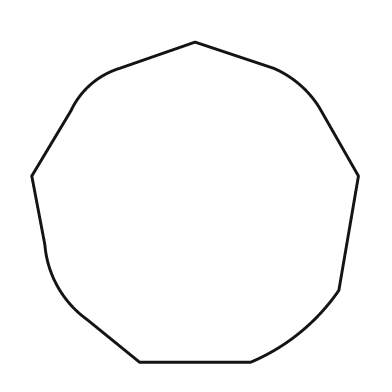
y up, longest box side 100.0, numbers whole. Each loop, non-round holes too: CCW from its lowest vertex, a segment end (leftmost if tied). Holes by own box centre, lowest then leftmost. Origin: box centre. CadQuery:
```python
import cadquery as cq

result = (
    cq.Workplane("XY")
    .moveTo(-17.0, -49.0)
    .lineTo(17.0, -49.0)
    .threePointArc((32.0, -40.0), (44.0, -27.0))
    .lineTo(50.0, 8.0)
    .lineTo(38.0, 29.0)
    .threePointArc((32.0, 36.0), (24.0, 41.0))
    .lineTo(0.0, 49.0)
    .lineTo(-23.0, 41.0)
    .threePointArc((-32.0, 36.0), (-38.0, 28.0))
    .lineTo(-50.0, 8.0)
    .lineTo(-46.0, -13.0)
    .threePointArc((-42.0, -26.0), (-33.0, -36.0))
    .close()
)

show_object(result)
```